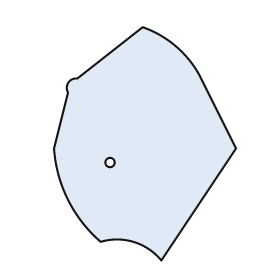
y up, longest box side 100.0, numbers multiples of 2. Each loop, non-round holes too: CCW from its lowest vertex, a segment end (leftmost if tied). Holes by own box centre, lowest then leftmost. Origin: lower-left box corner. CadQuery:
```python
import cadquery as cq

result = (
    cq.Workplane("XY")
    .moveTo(46.0, 0.0)
    .lineTo(78.0, 48.0)
    .lineTo(62.0, 80.0)
    .threePointArc((52.0, 92.0), (38.0, 100.0))
    .lineTo(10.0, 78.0)
    .threePointArc((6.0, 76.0), (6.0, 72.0))
    .lineTo(0.0, 48.0)
    .threePointArc((6.0, 26.0), (20.0, 8.0))
    .threePointArc((34.0, 8.0), (46.0, 0.0))
    .close()
    .moveTo(24.0, 42.0)
    .circle(2.0)
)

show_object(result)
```